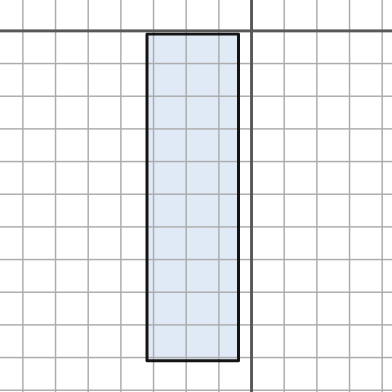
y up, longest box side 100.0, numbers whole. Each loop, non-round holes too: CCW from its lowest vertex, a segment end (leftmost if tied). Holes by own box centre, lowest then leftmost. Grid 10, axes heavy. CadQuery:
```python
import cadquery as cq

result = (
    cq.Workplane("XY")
    .moveTo(-32.0, -101.0)
    .lineTo(-4.0, -101.0)
    .lineTo(-4.0, -1.0)
    .lineTo(-32.0, -1.0)
    .close()
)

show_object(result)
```